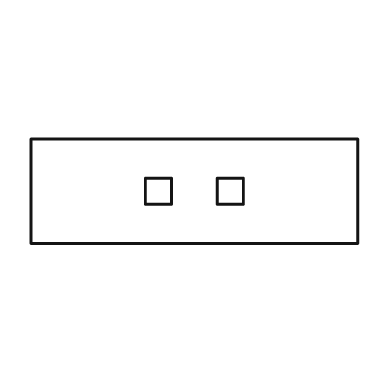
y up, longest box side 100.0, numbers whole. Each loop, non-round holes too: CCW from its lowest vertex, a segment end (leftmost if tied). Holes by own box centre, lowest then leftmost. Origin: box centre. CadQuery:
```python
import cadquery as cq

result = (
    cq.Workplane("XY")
    .moveTo(-50.0, -16.0)
    .lineTo(50.0, -16.0)
    .lineTo(50.0, 16.0)
    .lineTo(-50.0, 16.0)
    .close()
    .moveTo(-15.0, -4.0)
    .lineTo(-7.0, -4.0)
    .lineTo(-7.0, 4.0)
    .lineTo(-15.0, 4.0)
    .close()
    .moveTo(7.0, -4.0)
    .lineTo(15.0, -4.0)
    .lineTo(15.0, 4.0)
    .lineTo(7.0, 4.0)
    .close()
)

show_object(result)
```